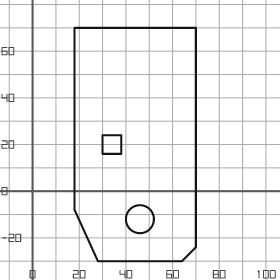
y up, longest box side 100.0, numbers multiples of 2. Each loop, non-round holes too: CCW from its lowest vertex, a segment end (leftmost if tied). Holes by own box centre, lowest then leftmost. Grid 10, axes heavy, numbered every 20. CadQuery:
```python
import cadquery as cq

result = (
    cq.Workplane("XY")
    .moveTo(28.0, -30.0)
    .lineTo(64.0, -30.0)
    .lineTo(70.0, -24.0)
    .lineTo(70.0, 70.0)
    .lineTo(18.0, 70.0)
    .lineTo(18.0, -8.0)
    .close()
    .moveTo(46.0, -12.0)
    .circle(6.0)
    .moveTo(30.0, 16.0)
    .lineTo(38.0, 16.0)
    .lineTo(38.0, 24.0)
    .lineTo(30.0, 24.0)
    .close()
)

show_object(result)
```